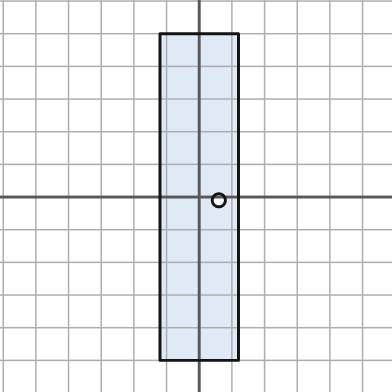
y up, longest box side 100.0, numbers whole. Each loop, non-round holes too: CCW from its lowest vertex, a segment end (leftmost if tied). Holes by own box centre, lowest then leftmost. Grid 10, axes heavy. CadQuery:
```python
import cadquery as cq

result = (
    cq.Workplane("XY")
    .moveTo(-12.0, -50.0)
    .lineTo(12.0, -50.0)
    .lineTo(12.0, 50.0)
    .lineTo(-12.0, 50.0)
    .close()
    .moveTo(6.0, -1.0)
    .circle(2.0)
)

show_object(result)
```